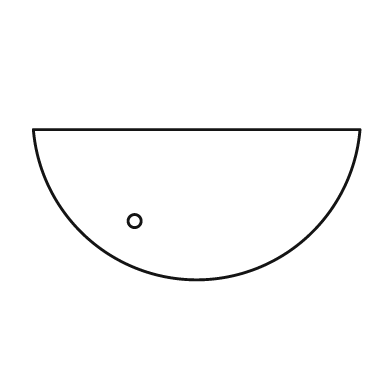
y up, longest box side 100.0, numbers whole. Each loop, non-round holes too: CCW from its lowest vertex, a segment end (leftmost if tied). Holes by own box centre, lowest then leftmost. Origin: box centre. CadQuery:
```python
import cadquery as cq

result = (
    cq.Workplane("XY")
    .moveTo(-50.0, 23.0)
    .threePointArc((0.0, -23.0), (50.0, 23.0))
    .close()
    .moveTo(-19.0, -5.0)
    .circle(2.0)
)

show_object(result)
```